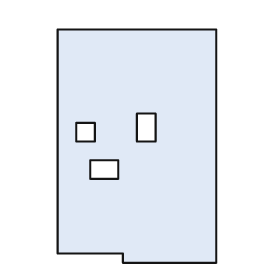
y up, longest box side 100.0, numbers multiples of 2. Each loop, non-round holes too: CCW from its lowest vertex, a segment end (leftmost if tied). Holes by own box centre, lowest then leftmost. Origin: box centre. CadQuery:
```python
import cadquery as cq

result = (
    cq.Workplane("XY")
    .moveTo(-6.0, -50.0)
    .lineTo(34.0, -50.0)
    .lineTo(34.0, 50.0)
    .lineTo(-34.0, 50.0)
    .lineTo(-34.0, -46.0)
    .lineTo(-6.0, -46.0)
    .close()
    .moveTo(-20.0, -14.0)
    .lineTo(-8.0, -14.0)
    .lineTo(-8.0, -6.0)
    .lineTo(-20.0, -6.0)
    .close()
    .moveTo(-26.0, 2.0)
    .lineTo(-18.0, 2.0)
    .lineTo(-18.0, 10.0)
    .lineTo(-26.0, 10.0)
    .close()
    .moveTo(0.0, 2.0)
    .lineTo(8.0, 2.0)
    .lineTo(8.0, 14.0)
    .lineTo(0.0, 14.0)
    .close()
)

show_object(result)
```